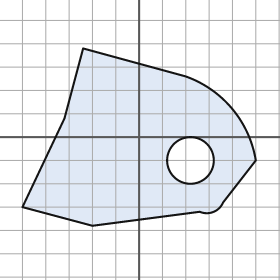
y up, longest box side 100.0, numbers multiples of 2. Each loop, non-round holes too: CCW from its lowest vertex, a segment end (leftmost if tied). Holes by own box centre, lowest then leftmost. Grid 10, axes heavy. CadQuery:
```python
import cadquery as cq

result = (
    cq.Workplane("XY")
    .moveTo(-20.0, -38.0)
    .lineTo(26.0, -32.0)
    .threePointArc((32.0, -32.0), (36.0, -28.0))
    .lineTo(50.0, -10.0)
    .threePointArc((40.0, 12.0), (20.0, 26.0))
    .lineTo(-24.0, 38.0)
    .lineTo(-32.0, 8.0)
    .lineTo(-50.0, -30.0)
    .close()
    .moveTo(22.0, -10.0)
    .circle(10.0)
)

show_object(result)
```